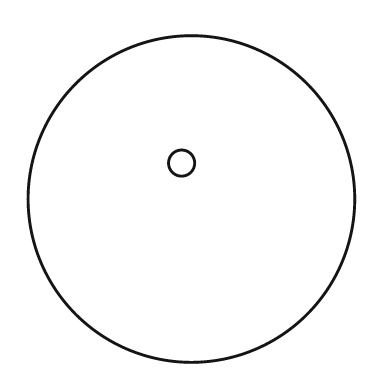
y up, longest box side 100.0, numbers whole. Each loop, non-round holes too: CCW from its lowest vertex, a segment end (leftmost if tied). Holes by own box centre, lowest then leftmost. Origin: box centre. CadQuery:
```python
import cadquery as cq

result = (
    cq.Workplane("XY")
    .moveTo(0.0, 0.0)
    .circle(50.0)
    .moveTo(-3.0, 11.0)
    .circle(4.0)
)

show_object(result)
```